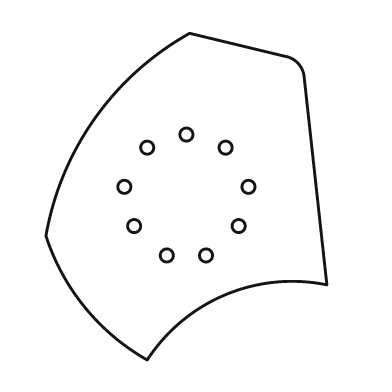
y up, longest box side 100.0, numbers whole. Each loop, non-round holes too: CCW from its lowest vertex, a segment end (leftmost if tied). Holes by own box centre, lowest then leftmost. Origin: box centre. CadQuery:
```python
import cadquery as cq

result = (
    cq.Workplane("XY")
    .moveTo(-12.0, -50.0)
    .threePointArc((12.0, -30.0), (43.0, -27.0))
    .lineTo(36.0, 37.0)
    .threePointArc((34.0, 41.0), (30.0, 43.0))
    .lineTo(1.0, 50.0)
    .threePointArc((-28.0, 24.0), (-43.0, -12.0))
    .threePointArc((-31.0, -34.0), (-12.0, -50.0))
    .close()
    .moveTo(-6.0, -18.0)
    .circle(2.0)
    .moveTo(6.0, -18.0)
    .circle(2.0)
    .moveTo(-16.0, -9.0)
    .circle(2.0)
    .moveTo(16.0, -9.0)
    .circle(2.0)
    .moveTo(-19.0, 3.0)
    .circle(2.0)
    .moveTo(19.0, 3.0)
    .circle(2.0)
    .moveTo(-12.0, 15.0)
    .circle(2.0)
    .moveTo(12.0, 15.0)
    .circle(2.0)
    .moveTo(0.0, 19.0)
    .circle(2.0)
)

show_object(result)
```